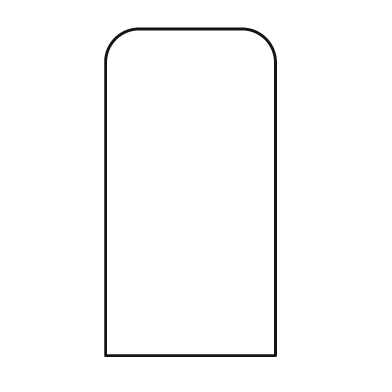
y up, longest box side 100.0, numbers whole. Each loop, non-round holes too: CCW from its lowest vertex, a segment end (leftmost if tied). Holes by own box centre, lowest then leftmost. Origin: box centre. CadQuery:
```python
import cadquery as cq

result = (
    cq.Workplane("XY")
    .moveTo(-26.0, -50.0)
    .lineTo(26.0, -50.0)
    .lineTo(26.0, 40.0)
    .threePointArc((23.0, 47.0), (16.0, 50.0))
    .lineTo(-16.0, 50.0)
    .threePointArc((-23.0, 47.0), (-26.0, 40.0))
    .close()
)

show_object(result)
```